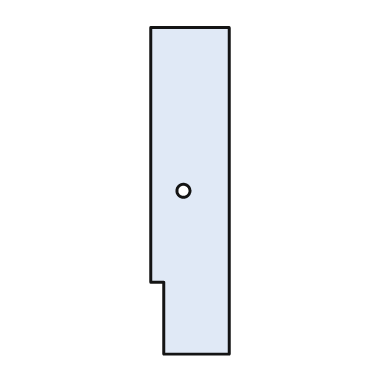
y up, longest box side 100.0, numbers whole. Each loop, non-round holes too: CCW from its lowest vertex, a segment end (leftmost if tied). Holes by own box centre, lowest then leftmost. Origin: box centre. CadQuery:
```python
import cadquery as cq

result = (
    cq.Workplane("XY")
    .moveTo(-8.0, -50.0)
    .lineTo(12.0, -50.0)
    .lineTo(12.0, 50.0)
    .lineTo(-12.0, 50.0)
    .lineTo(-12.0, -28.0)
    .lineTo(-8.0, -28.0)
    .close()
    .moveTo(-2.0, 0.0)
    .circle(2.0)
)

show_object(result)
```